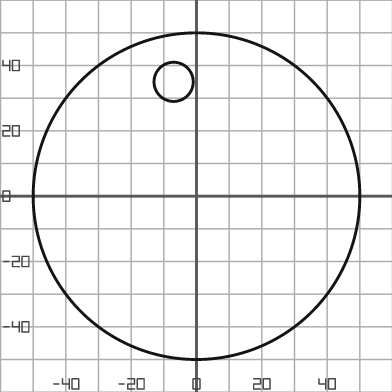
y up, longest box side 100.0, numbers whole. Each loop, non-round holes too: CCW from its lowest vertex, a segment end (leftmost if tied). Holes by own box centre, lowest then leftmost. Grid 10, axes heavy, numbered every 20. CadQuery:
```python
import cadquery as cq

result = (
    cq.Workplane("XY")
    .moveTo(0.0, 0.0)
    .circle(50.0)
    .moveTo(-7.0, 35.0)
    .circle(6.0)
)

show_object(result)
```